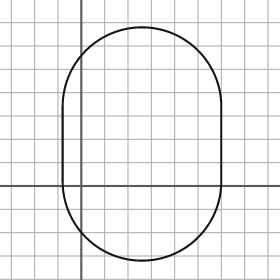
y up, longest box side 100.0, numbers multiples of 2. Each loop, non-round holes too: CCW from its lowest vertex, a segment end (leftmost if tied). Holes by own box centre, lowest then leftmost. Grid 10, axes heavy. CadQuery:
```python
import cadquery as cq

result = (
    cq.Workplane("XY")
    .moveTo(-8.0, 2.0)
    .threePointArc((26.0, -32.0), (60.0, 2.0))
    .lineTo(60.0, 34.0)
    .threePointArc((26.0, 68.0), (-8.0, 34.0))
    .close()
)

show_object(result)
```